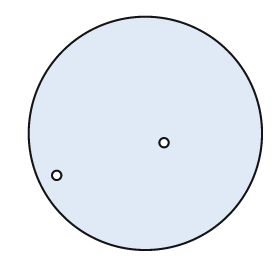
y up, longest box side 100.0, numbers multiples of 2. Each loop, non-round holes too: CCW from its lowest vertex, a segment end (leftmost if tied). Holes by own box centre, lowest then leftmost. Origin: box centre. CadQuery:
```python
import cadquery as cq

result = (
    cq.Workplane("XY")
    .moveTo(0.0, 0.0)
    .circle(50.0)
    .moveTo(-38.0, -18.0)
    .circle(2.0)
    .moveTo(8.0, -4.0)
    .circle(2.0)
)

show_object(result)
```